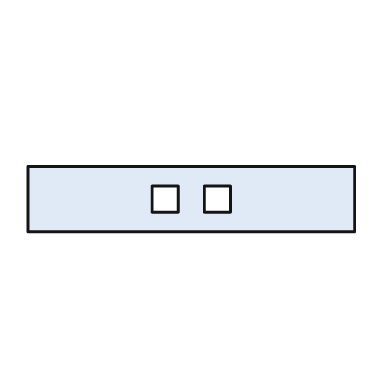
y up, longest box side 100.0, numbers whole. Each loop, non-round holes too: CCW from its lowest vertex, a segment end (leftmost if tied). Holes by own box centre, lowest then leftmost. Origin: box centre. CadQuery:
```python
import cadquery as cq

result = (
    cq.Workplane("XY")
    .moveTo(-50.0, -10.0)
    .lineTo(50.0, -10.0)
    .lineTo(50.0, 10.0)
    .lineTo(-50.0, 10.0)
    .close()
    .moveTo(-12.0, -4.0)
    .lineTo(-4.0, -4.0)
    .lineTo(-4.0, 4.0)
    .lineTo(-12.0, 4.0)
    .close()
    .moveTo(4.0, -4.0)
    .lineTo(12.0, -4.0)
    .lineTo(12.0, 4.0)
    .lineTo(4.0, 4.0)
    .close()
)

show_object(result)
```